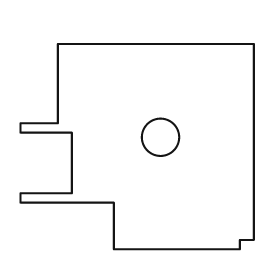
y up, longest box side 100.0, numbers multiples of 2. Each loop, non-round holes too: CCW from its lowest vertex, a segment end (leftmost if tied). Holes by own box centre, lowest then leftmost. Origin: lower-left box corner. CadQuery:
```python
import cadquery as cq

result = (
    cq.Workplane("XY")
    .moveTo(40.0, 0.0)
    .lineTo(94.0, 0.0)
    .lineTo(94.0, 4.0)
    .lineTo(100.0, 4.0)
    .lineTo(100.0, 88.0)
    .lineTo(16.0, 88.0)
    .lineTo(16.0, 54.0)
    .lineTo(0.0, 54.0)
    .lineTo(0.0, 50.0)
    .lineTo(22.0, 50.0)
    .lineTo(22.0, 24.0)
    .lineTo(0.0, 24.0)
    .lineTo(0.0, 20.0)
    .lineTo(40.0, 20.0)
    .close()
    .moveTo(60.0, 48.0)
    .circle(8.0)
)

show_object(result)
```